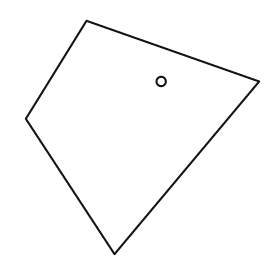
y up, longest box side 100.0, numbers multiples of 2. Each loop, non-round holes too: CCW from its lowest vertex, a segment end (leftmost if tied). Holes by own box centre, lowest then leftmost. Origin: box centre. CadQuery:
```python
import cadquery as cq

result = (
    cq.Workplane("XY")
    .moveTo(-12.0, -50.0)
    .lineTo(50.0, 24.0)
    .lineTo(-24.0, 50.0)
    .lineTo(-50.0, 8.0)
    .close()
    .moveTo(8.0, 24.0)
    .circle(2.0)
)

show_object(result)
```